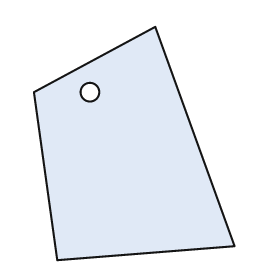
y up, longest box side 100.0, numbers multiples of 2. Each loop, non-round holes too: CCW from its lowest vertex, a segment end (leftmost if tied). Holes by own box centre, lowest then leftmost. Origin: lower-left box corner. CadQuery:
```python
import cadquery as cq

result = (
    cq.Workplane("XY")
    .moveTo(10.0, 0.0)
    .lineTo(86.0, 6.0)
    .lineTo(52.0, 100.0)
    .lineTo(0.0, 72.0)
    .close()
    .moveTo(24.0, 72.0)
    .circle(4.0)
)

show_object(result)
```